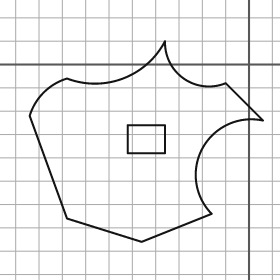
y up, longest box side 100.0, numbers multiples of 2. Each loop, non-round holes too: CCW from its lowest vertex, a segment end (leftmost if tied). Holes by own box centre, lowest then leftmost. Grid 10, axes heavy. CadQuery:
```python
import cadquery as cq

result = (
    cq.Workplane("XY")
    .moveTo(-46.0, -76.0)
    .lineTo(-16.0, -64.0)
    .threePointArc((-20.0, -36.0), (6.0, -24.0))
    .lineTo(-10.0, -8.0)
    .threePointArc((-28.0, -6.0), (-36.0, 10.0))
    .threePointArc((-54.0, -6.0), (-78.0, -6.0))
    .threePointArc((-88.0, -12.0), (-94.0, -22.0))
    .lineTo(-78.0, -66.0)
    .close()
    .moveTo(-52.0, -38.0)
    .lineTo(-36.0, -38.0)
    .lineTo(-36.0, -26.0)
    .lineTo(-52.0, -26.0)
    .close()
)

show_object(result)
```